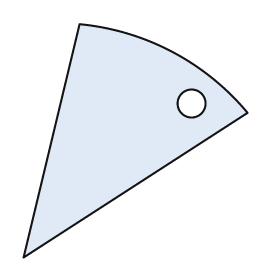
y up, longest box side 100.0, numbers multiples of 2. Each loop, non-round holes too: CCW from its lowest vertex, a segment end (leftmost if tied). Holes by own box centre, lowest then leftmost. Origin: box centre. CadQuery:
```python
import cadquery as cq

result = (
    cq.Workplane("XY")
    .moveTo(-48.0, -50.0)
    .lineTo(48.0, 12.0)
    .threePointArc((16.0, 38.0), (-24.0, 50.0))
    .close()
    .moveTo(24.0, 16.0)
    .circle(6.0)
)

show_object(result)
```